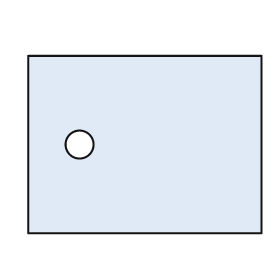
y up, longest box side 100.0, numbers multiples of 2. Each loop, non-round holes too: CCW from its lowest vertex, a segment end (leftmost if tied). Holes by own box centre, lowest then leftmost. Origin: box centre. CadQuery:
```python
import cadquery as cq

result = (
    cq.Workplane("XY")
    .moveTo(-50.0, -38.0)
    .lineTo(50.0, -38.0)
    .lineTo(50.0, 38.0)
    .lineTo(-50.0, 38.0)
    .close()
    .moveTo(-28.0, 0.0)
    .circle(6.0)
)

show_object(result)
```